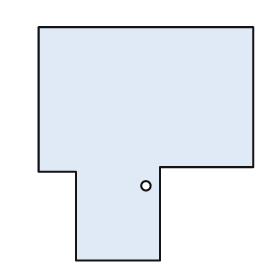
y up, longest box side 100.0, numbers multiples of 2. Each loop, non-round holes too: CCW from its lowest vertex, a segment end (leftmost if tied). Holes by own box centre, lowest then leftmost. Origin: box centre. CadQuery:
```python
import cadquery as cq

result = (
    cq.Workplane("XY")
    .moveTo(-30.0, -50.0)
    .lineTo(6.0, -50.0)
    .lineTo(6.0, -10.0)
    .lineTo(46.0, -10.0)
    .lineTo(46.0, 50.0)
    .lineTo(-46.0, 50.0)
    .lineTo(-46.0, -12.0)
    .lineTo(-30.0, -12.0)
    .close()
    .moveTo(0.0, -18.0)
    .circle(2.0)
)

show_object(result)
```